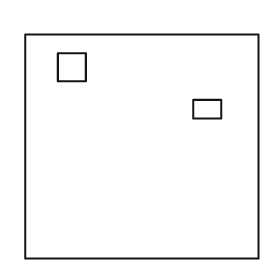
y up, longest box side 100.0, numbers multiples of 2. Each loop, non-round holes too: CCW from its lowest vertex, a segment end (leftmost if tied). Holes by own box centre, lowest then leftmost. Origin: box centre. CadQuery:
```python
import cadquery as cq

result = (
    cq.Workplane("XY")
    .moveTo(-50.0, -48.0)
    .lineTo(50.0, -48.0)
    .lineTo(50.0, 48.0)
    .lineTo(-50.0, 48.0)
    .close()
    .moveTo(22.0, 12.0)
    .lineTo(34.0, 12.0)
    .lineTo(34.0, 20.0)
    .lineTo(22.0, 20.0)
    .close()
    .moveTo(-36.0, 28.0)
    .lineTo(-24.0, 28.0)
    .lineTo(-24.0, 40.0)
    .lineTo(-36.0, 40.0)
    .close()
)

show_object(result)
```